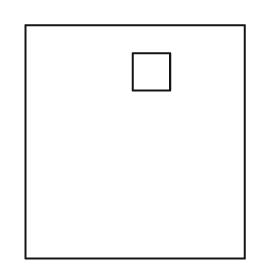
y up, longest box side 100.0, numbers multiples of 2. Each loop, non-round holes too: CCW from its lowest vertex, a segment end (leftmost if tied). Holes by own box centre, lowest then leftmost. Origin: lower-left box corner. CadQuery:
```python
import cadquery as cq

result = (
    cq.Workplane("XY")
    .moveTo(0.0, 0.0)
    .lineTo(94.0, 0.0)
    .lineTo(94.0, 100.0)
    .lineTo(0.0, 100.0)
    .close()
    .moveTo(46.0, 72.0)
    .lineTo(62.0, 72.0)
    .lineTo(62.0, 88.0)
    .lineTo(46.0, 88.0)
    .close()
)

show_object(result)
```